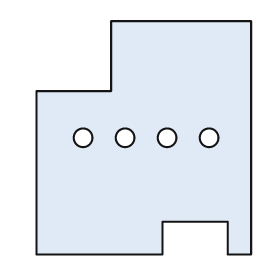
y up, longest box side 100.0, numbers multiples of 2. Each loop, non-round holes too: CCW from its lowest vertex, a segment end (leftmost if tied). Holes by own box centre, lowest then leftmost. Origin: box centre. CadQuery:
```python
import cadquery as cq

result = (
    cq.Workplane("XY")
    .moveTo(-46.0, -50.0)
    .lineTo(8.0, -50.0)
    .lineTo(8.0, -36.0)
    .lineTo(36.0, -36.0)
    .lineTo(36.0, -50.0)
    .lineTo(46.0, -50.0)
    .lineTo(46.0, 50.0)
    .lineTo(-14.0, 50.0)
    .lineTo(-14.0, 20.0)
    .lineTo(-46.0, 20.0)
    .close()
    .moveTo(-26.0, 0.0)
    .circle(4.0)
    .moveTo(-8.0, 0.0)
    .circle(4.0)
    .moveTo(10.0, 0.0)
    .circle(4.0)
    .moveTo(28.0, 0.0)
    .circle(4.0)
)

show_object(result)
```